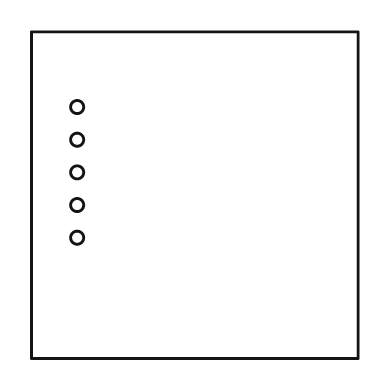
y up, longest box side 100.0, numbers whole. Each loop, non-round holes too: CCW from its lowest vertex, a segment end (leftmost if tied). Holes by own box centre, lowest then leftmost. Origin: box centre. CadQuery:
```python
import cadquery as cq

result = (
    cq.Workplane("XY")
    .moveTo(-50.0, -50.0)
    .lineTo(50.0, -50.0)
    .lineTo(50.0, 50.0)
    .lineTo(-50.0, 50.0)
    .close()
    .moveTo(-36.0, -13.0)
    .circle(2.0)
    .moveTo(-36.0, -3.0)
    .circle(2.0)
    .moveTo(-36.0, 7.0)
    .circle(2.0)
    .moveTo(-36.0, 17.0)
    .circle(2.0)
    .moveTo(-36.0, 27.0)
    .circle(2.0)
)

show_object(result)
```